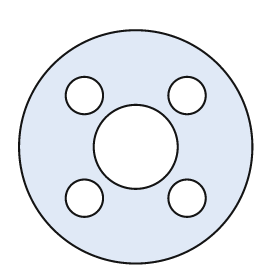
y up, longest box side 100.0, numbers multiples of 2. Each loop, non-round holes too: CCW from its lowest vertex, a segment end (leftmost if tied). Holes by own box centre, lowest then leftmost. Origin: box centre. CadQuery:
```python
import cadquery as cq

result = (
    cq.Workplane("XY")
    .moveTo(0.0, 0.0)
    .circle(50.0)
    .moveTo(-22.0, -22.0)
    .circle(8.0)
    .moveTo(22.0, -22.0)
    .circle(8.0)
    .moveTo(0.0, 0.0)
    .circle(18.0)
    .moveTo(-22.0, 22.0)
    .circle(8.0)
    .moveTo(22.0, 22.0)
    .circle(8.0)
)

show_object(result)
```